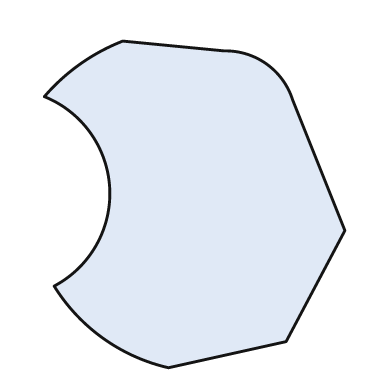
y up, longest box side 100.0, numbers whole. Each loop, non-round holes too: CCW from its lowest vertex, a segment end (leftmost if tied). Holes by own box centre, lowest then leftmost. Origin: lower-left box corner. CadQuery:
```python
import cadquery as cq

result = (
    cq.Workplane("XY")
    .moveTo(38.0, 0.0)
    .lineTo(74.0, 8.0)
    .lineTo(92.0, 42.0)
    .lineTo(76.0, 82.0)
    .threePointArc((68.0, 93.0), (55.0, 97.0))
    .lineTo(24.0, 100.0)
    .threePointArc((11.0, 93.0), (0.0, 83.0))
    .threePointArc((20.0, 55.0), (3.0, 25.0))
    .threePointArc((18.0, 9.0), (38.0, 0.0))
    .close()
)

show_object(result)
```